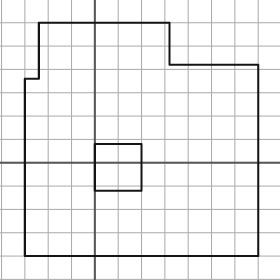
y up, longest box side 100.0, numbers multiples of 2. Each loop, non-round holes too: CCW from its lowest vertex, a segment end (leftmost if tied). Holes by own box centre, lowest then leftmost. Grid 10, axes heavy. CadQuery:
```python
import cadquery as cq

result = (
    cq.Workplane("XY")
    .moveTo(-30.0, -40.0)
    .lineTo(70.0, -40.0)
    .lineTo(70.0, 42.0)
    .lineTo(32.0, 42.0)
    .lineTo(32.0, 60.0)
    .lineTo(-24.0, 60.0)
    .lineTo(-24.0, 36.0)
    .lineTo(-30.0, 36.0)
    .close()
    .moveTo(0.0, -12.0)
    .lineTo(20.0, -12.0)
    .lineTo(20.0, 8.0)
    .lineTo(0.0, 8.0)
    .close()
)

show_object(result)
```